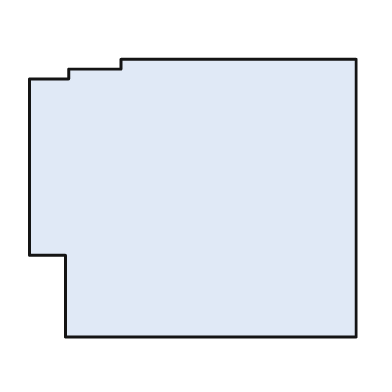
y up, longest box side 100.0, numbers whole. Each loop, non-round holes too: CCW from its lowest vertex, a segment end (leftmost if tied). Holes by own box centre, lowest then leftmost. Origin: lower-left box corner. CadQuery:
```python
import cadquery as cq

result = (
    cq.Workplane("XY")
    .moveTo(11.0, 0.0)
    .lineTo(100.0, 0.0)
    .lineTo(100.0, 85.0)
    .lineTo(28.0, 85.0)
    .lineTo(28.0, 82.0)
    .lineTo(12.0, 82.0)
    .lineTo(12.0, 79.0)
    .lineTo(0.0, 79.0)
    .lineTo(0.0, 25.0)
    .lineTo(11.0, 25.0)
    .close()
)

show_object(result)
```